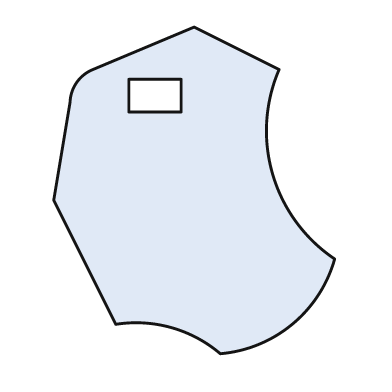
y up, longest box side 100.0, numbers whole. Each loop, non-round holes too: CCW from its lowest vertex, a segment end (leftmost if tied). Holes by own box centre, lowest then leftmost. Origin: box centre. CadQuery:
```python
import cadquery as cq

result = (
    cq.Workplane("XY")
    .moveTo(8.0, -50.0)
    .threePointArc((30.0, -41.0), (43.0, -21.0))
    .threePointArc((24.0, 5.0), (26.0, 37.0))
    .lineTo(0.0, 50.0)
    .lineTo(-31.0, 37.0)
    .threePointArc((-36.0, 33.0), (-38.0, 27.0))
    .lineTo(-43.0, -3.0)
    .lineTo(-24.0, -41.0)
    .threePointArc((-7.0, -42.0), (8.0, -50.0))
    .close()
    .moveTo(-20.0, 24.0)
    .lineTo(-4.0, 24.0)
    .lineTo(-4.0, 34.0)
    .lineTo(-20.0, 34.0)
    .close()
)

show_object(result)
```